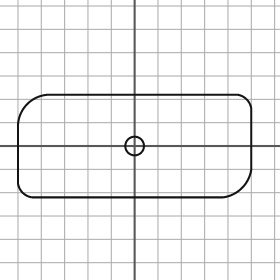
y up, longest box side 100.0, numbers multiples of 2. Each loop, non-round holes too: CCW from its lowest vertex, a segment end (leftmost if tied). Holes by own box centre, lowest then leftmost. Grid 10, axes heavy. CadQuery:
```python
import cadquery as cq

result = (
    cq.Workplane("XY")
    .moveTo(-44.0, -22.0)
    .lineTo(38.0, -22.0)
    .threePointArc((46.0, -18.0), (50.0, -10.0))
    .lineTo(50.0, 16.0)
    .threePointArc((48.0, 20.0), (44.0, 22.0))
    .lineTo(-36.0, 22.0)
    .threePointArc((-46.0, 18.0), (-50.0, 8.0))
    .lineTo(-50.0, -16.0)
    .threePointArc((-48.0, -20.0), (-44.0, -22.0))
    .close()
    .moveTo(0.0, 0.0)
    .circle(4.0)
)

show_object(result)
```